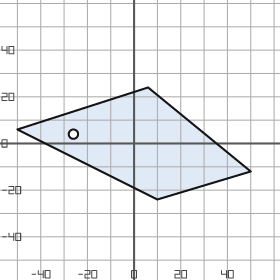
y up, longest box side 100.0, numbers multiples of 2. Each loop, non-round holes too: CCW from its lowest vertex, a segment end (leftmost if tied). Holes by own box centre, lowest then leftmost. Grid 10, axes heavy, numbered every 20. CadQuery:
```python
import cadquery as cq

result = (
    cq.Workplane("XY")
    .moveTo(10.0, -24.0)
    .lineTo(50.0, -12.0)
    .lineTo(6.0, 24.0)
    .lineTo(-50.0, 6.0)
    .close()
    .moveTo(-26.0, 4.0)
    .circle(2.0)
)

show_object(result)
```